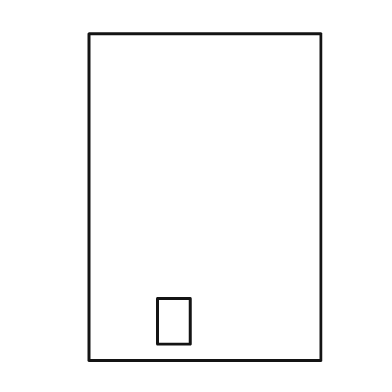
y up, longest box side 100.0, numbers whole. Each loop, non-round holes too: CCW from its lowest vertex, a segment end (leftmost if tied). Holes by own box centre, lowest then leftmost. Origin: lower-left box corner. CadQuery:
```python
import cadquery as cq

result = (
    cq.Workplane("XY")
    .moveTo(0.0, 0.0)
    .lineTo(71.0, 0.0)
    .lineTo(71.0, 100.0)
    .lineTo(0.0, 100.0)
    .close()
    .moveTo(21.0, 5.0)
    .lineTo(31.0, 5.0)
    .lineTo(31.0, 19.0)
    .lineTo(21.0, 19.0)
    .close()
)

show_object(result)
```